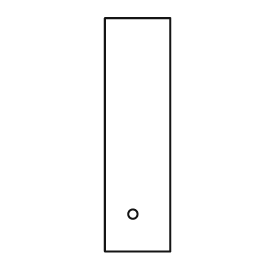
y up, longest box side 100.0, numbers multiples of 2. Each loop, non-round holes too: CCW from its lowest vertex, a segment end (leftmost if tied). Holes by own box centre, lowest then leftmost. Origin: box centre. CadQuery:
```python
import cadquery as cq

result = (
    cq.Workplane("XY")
    .moveTo(-14.0, -50.0)
    .lineTo(14.0, -50.0)
    .lineTo(14.0, 50.0)
    .lineTo(-14.0, 50.0)
    .close()
    .moveTo(-2.0, -34.0)
    .circle(2.0)
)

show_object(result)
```